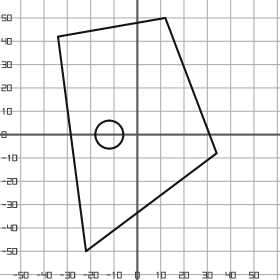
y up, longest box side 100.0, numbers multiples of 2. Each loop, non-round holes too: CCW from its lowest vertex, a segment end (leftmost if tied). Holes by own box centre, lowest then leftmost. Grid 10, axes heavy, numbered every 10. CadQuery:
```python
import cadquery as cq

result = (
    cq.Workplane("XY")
    .moveTo(-22.0, -50.0)
    .lineTo(34.0, -8.0)
    .lineTo(12.0, 50.0)
    .lineTo(-34.0, 42.0)
    .close()
    .moveTo(-12.0, 0.0)
    .circle(6.0)
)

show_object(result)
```